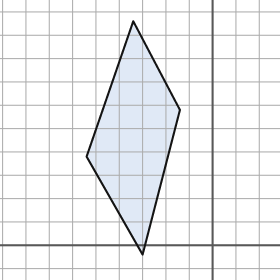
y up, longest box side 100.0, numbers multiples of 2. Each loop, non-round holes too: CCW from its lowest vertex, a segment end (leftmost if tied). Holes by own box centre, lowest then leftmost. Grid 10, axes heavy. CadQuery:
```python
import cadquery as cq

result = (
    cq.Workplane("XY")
    .moveTo(-30.0, -4.0)
    .lineTo(-14.0, 58.0)
    .lineTo(-34.0, 96.0)
    .lineTo(-54.0, 38.0)
    .close()
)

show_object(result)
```